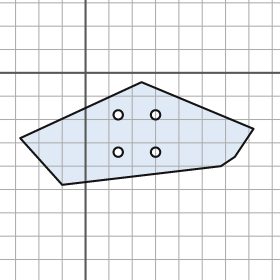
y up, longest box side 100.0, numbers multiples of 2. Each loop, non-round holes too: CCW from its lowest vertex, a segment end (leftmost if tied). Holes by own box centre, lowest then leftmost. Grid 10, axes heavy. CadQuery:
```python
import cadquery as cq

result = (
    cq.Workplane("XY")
    .moveTo(-10.0, -48.0)
    .lineTo(58.0, -40.0)
    .lineTo(64.0, -36.0)
    .lineTo(72.0, -24.0)
    .lineTo(24.0, -4.0)
    .lineTo(-28.0, -28.0)
    .close()
    .moveTo(14.0, -34.0)
    .circle(2.0)
    .moveTo(30.0, -34.0)
    .circle(2.0)
    .moveTo(14.0, -18.0)
    .circle(2.0)
    .moveTo(30.0, -18.0)
    .circle(2.0)
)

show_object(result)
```